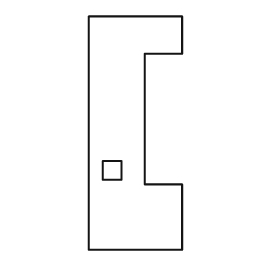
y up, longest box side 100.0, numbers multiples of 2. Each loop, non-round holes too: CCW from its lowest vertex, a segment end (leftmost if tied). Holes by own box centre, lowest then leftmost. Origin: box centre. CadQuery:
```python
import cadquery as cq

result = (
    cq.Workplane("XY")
    .moveTo(-20.0, -50.0)
    .lineTo(20.0, -50.0)
    .lineTo(20.0, -22.0)
    .lineTo(4.0, -22.0)
    .lineTo(4.0, 34.0)
    .lineTo(20.0, 34.0)
    .lineTo(20.0, 50.0)
    .lineTo(-20.0, 50.0)
    .close()
    .moveTo(-14.0, -20.0)
    .lineTo(-6.0, -20.0)
    .lineTo(-6.0, -12.0)
    .lineTo(-14.0, -12.0)
    .close()
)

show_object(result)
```